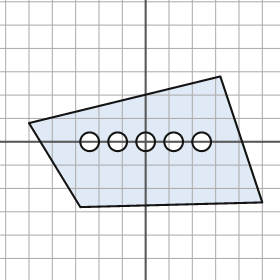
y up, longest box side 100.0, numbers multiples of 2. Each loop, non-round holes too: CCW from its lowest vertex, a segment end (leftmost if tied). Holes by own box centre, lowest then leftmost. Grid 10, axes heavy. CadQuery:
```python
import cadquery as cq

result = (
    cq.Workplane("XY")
    .moveTo(-28.0, -28.0)
    .lineTo(50.0, -26.0)
    .lineTo(32.0, 28.0)
    .lineTo(-50.0, 8.0)
    .close()
    .moveTo(-24.0, 0.0)
    .circle(4.0)
    .moveTo(-12.0, 0.0)
    .circle(4.0)
    .moveTo(0.0, 0.0)
    .circle(4.0)
    .moveTo(12.0, 0.0)
    .circle(4.0)
    .moveTo(24.0, 0.0)
    .circle(4.0)
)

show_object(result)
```